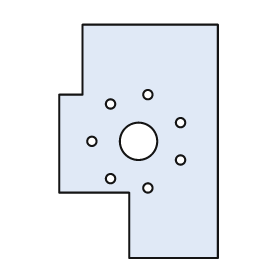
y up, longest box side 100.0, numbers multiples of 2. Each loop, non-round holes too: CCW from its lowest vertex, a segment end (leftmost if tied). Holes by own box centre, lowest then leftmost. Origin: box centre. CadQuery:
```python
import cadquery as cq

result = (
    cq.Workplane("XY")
    .moveTo(-4.0, -50.0)
    .lineTo(34.0, -50.0)
    .lineTo(34.0, 50.0)
    .lineTo(-24.0, 50.0)
    .lineTo(-24.0, 20.0)
    .lineTo(-34.0, 20.0)
    .lineTo(-34.0, -22.0)
    .lineTo(-4.0, -22.0)
    .close()
    .moveTo(4.0, -20.0)
    .circle(2.0)
    .moveTo(-12.0, -16.0)
    .circle(2.0)
    .moveTo(18.0, -8.0)
    .circle(2.0)
    .moveTo(-20.0, 0.0)
    .circle(2.0)
    .moveTo(0.0, 0.0)
    .circle(8.0)
    .moveTo(18.0, 8.0)
    .circle(2.0)
    .moveTo(-12.0, 16.0)
    .circle(2.0)
    .moveTo(4.0, 20.0)
    .circle(2.0)
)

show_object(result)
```